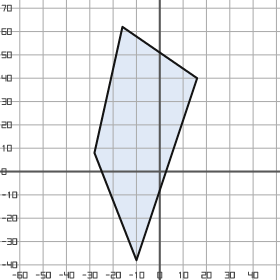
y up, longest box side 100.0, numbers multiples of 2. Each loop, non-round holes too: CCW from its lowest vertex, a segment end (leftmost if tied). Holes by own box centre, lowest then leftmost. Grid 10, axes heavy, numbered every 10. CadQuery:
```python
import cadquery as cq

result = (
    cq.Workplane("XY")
    .moveTo(-10.0, -38.0)
    .lineTo(16.0, 40.0)
    .lineTo(-16.0, 62.0)
    .lineTo(-28.0, 8.0)
    .close()
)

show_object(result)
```